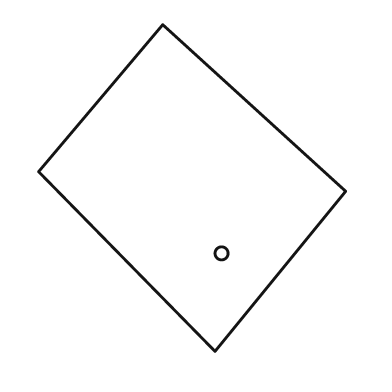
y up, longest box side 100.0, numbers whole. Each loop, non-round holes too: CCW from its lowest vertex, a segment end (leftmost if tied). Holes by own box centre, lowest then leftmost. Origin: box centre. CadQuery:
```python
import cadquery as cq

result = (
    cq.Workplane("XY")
    .moveTo(7.0, -50.0)
    .lineTo(47.0, -1.0)
    .lineTo(-9.0, 50.0)
    .lineTo(-47.0, 5.0)
    .close()
    .moveTo(9.0, -20.0)
    .circle(2.0)
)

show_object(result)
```